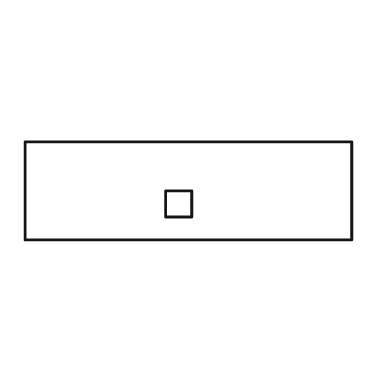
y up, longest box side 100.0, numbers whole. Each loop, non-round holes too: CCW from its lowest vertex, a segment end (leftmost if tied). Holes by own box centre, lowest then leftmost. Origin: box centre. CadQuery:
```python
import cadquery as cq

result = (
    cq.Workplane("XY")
    .moveTo(-50.0, -15.0)
    .lineTo(50.0, -15.0)
    .lineTo(50.0, 15.0)
    .lineTo(-50.0, 15.0)
    .close()
    .moveTo(-7.0, -8.0)
    .lineTo(1.0, -8.0)
    .lineTo(1.0, 0.0)
    .lineTo(-7.0, 0.0)
    .close()
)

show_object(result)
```